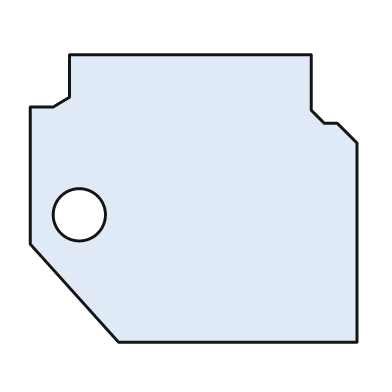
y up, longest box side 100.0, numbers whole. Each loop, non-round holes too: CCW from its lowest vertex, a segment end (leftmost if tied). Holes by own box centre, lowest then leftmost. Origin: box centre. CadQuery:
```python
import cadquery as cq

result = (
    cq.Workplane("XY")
    .moveTo(-23.0, -44.0)
    .lineTo(50.0, -44.0)
    .lineTo(50.0, 17.0)
    .lineTo(44.0, 23.0)
    .lineTo(40.0, 23.0)
    .lineTo(36.0, 27.0)
    .lineTo(36.0, 44.0)
    .lineTo(-38.0, 44.0)
    .lineTo(-38.0, 31.0)
    .lineTo(-43.0, 28.0)
    .lineTo(-50.0, 28.0)
    .lineTo(-50.0, -14.0)
    .close()
    .moveTo(-35.0, -5.0)
    .circle(8.0)
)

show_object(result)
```